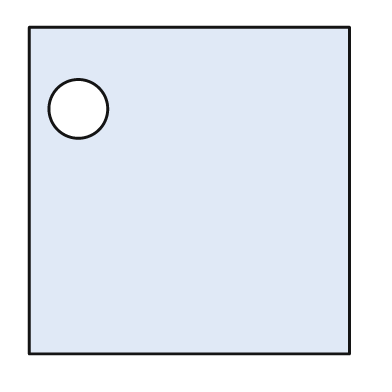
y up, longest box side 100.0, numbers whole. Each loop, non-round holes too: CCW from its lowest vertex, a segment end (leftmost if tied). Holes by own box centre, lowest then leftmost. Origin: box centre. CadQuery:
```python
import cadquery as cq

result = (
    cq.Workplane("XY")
    .moveTo(-49.0, -50.0)
    .lineTo(49.0, -50.0)
    .lineTo(49.0, 50.0)
    .lineTo(-49.0, 50.0)
    .close()
    .moveTo(-34.0, 25.0)
    .circle(9.0)
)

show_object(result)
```